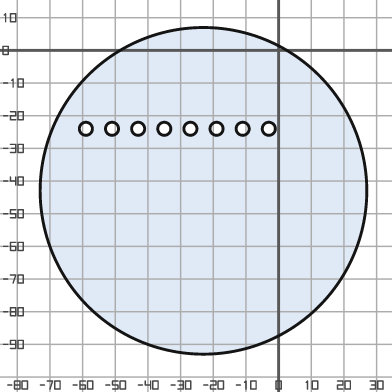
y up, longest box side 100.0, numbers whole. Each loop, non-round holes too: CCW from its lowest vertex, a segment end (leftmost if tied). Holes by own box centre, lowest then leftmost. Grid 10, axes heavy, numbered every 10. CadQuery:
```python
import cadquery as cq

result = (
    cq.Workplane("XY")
    .moveTo(-23.0, -43.0)
    .circle(50.0)
    .moveTo(-59.0, -24.0)
    .circle(2.0)
    .moveTo(-51.0, -24.0)
    .circle(2.0)
    .moveTo(-43.0, -24.0)
    .circle(2.0)
    .moveTo(-35.0, -24.0)
    .circle(2.0)
    .moveTo(-27.0, -24.0)
    .circle(2.0)
    .moveTo(-19.0, -24.0)
    .circle(2.0)
    .moveTo(-11.0, -24.0)
    .circle(2.0)
    .moveTo(-3.0, -24.0)
    .circle(2.0)
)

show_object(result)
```